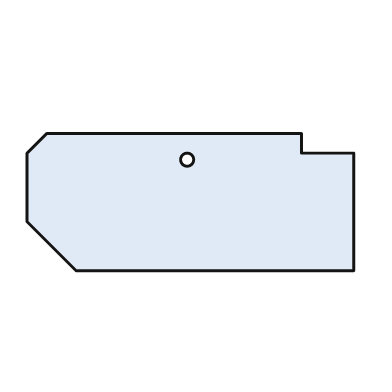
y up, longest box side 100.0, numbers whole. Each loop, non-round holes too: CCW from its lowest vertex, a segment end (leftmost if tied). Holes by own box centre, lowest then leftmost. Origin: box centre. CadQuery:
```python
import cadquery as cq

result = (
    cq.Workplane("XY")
    .moveTo(-35.0, -21.0)
    .lineTo(50.0, -21.0)
    .lineTo(50.0, 15.0)
    .lineTo(34.0, 15.0)
    .lineTo(34.0, 21.0)
    .lineTo(-44.0, 21.0)
    .lineTo(-50.0, 15.0)
    .lineTo(-50.0, -6.0)
    .close()
    .moveTo(-1.0, 13.0)
    .circle(2.0)
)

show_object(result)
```